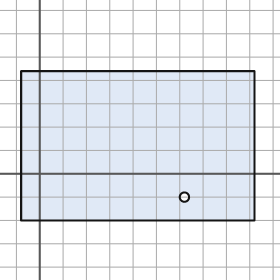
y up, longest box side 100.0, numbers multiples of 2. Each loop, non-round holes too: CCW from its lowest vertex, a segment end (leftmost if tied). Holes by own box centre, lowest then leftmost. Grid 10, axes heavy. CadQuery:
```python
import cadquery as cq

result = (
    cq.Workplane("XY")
    .moveTo(-8.0, -20.0)
    .lineTo(92.0, -20.0)
    .lineTo(92.0, 44.0)
    .lineTo(-8.0, 44.0)
    .close()
    .moveTo(62.0, -10.0)
    .circle(2.0)
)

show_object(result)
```